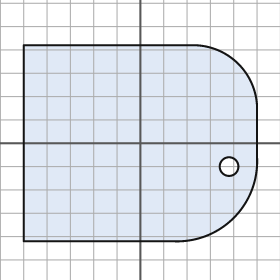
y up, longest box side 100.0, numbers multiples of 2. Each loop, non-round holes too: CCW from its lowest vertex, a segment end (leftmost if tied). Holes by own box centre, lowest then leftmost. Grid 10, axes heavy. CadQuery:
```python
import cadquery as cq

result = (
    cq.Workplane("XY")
    .moveTo(-50.0, -42.0)
    .lineTo(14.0, -42.0)
    .threePointArc((40.0, -32.0), (50.0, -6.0))
    .lineTo(50.0, 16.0)
    .threePointArc((42.0, 34.0), (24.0, 42.0))
    .lineTo(-50.0, 42.0)
    .close()
    .moveTo(38.0, -10.0)
    .circle(4.0)
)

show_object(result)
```